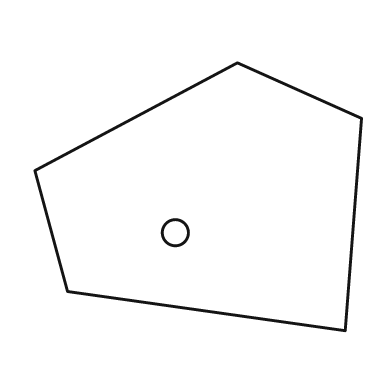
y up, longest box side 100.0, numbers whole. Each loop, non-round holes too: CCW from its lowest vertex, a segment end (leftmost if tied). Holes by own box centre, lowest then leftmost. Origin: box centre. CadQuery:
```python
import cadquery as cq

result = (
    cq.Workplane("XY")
    .moveTo(45.0, -41.0)
    .lineTo(50.0, 24.0)
    .lineTo(12.0, 41.0)
    .lineTo(-50.0, 8.0)
    .lineTo(-40.0, -29.0)
    .close()
    .moveTo(-7.0, -11.0)
    .circle(4.0)
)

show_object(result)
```